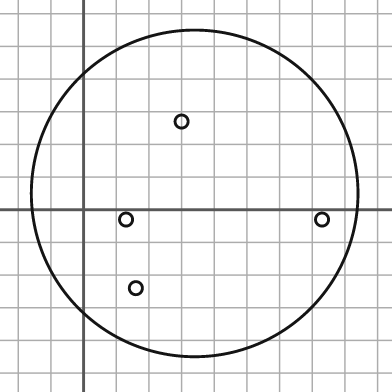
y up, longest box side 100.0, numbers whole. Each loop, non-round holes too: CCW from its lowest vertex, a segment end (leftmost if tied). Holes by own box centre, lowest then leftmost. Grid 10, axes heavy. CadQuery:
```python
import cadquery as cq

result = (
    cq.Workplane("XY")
    .moveTo(34.0, 5.0)
    .circle(50.0)
    .moveTo(16.0, -24.0)
    .circle(2.0)
    .moveTo(13.0, -3.0)
    .circle(2.0)
    .moveTo(73.0, -3.0)
    .circle(2.0)
    .moveTo(30.0, 27.0)
    .circle(2.0)
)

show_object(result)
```